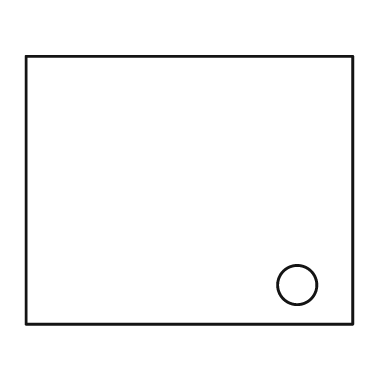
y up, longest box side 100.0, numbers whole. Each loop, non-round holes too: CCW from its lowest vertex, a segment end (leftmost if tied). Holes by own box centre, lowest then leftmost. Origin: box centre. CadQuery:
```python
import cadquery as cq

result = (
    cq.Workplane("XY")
    .moveTo(-50.0, -41.0)
    .lineTo(50.0, -41.0)
    .lineTo(50.0, 41.0)
    .lineTo(-50.0, 41.0)
    .close()
    .moveTo(33.0, -29.0)
    .circle(6.0)
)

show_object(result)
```